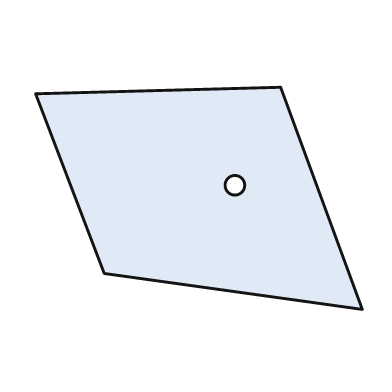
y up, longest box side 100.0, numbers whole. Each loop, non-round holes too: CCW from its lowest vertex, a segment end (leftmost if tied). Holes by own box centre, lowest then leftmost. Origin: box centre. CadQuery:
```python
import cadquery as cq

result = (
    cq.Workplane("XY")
    .moveTo(50.0, -34.0)
    .lineTo(25.0, 34.0)
    .lineTo(-50.0, 32.0)
    .lineTo(-29.0, -23.0)
    .close()
    .moveTo(11.0, 4.0)
    .circle(3.0)
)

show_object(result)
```